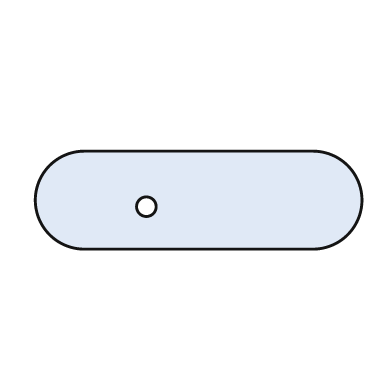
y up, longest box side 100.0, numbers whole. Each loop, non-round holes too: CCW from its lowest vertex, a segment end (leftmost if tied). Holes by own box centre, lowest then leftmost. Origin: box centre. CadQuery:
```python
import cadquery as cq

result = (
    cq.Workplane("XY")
    .moveTo(-35.0, -15.0)
    .lineTo(35.0, -15.0)
    .threePointArc((50.0, 0.0), (35.0, 15.0))
    .lineTo(-35.0, 15.0)
    .threePointArc((-50.0, 0.0), (-35.0, -15.0))
    .close()
    .moveTo(-16.0, -2.0)
    .circle(3.0)
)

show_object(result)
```